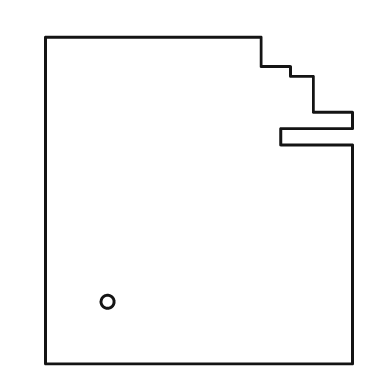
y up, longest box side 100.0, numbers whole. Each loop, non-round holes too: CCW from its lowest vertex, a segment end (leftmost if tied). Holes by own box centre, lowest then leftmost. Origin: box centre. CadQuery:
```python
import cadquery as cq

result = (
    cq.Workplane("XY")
    .moveTo(-47.0, -50.0)
    .lineTo(47.0, -50.0)
    .lineTo(47.0, 17.0)
    .lineTo(25.0, 17.0)
    .lineTo(25.0, 22.0)
    .lineTo(47.0, 22.0)
    .lineTo(47.0, 27.0)
    .lineTo(35.0, 27.0)
    .lineTo(35.0, 38.0)
    .lineTo(28.0, 38.0)
    .lineTo(28.0, 41.0)
    .lineTo(19.0, 41.0)
    .lineTo(19.0, 50.0)
    .lineTo(-47.0, 50.0)
    .close()
    .moveTo(-28.0, -31.0)
    .circle(2.0)
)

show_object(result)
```